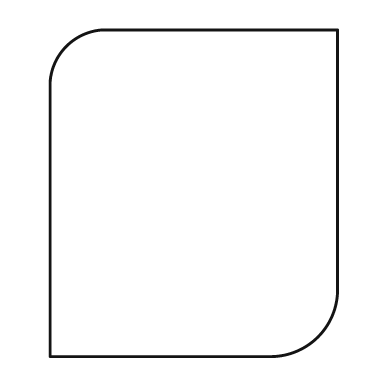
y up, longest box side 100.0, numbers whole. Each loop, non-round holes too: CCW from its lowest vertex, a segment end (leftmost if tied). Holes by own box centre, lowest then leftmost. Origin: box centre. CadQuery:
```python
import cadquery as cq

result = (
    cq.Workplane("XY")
    .moveTo(-44.0, -50.0)
    .lineTo(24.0, -50.0)
    .threePointArc((38.0, -44.0), (44.0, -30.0))
    .lineTo(44.0, 50.0)
    .lineTo(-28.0, 50.0)
    .threePointArc((-39.0, 45.0), (-44.0, 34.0))
    .close()
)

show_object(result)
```